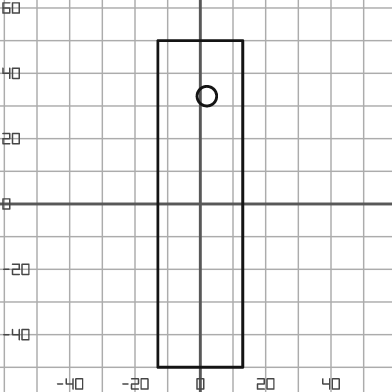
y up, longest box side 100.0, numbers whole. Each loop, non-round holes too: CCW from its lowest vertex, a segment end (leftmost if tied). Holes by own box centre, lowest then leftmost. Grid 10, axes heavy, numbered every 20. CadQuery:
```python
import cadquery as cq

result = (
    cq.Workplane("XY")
    .moveTo(-13.0, -50.0)
    .lineTo(13.0, -50.0)
    .lineTo(13.0, 50.0)
    .lineTo(-13.0, 50.0)
    .close()
    .moveTo(2.0, 33.0)
    .circle(3.0)
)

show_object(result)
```